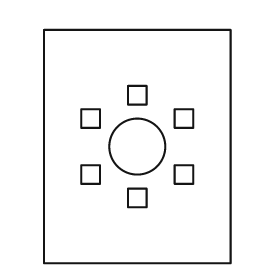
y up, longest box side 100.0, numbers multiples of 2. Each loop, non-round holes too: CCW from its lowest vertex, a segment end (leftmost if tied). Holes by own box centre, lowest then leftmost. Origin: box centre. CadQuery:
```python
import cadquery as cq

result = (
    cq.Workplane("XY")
    .moveTo(-40.0, -50.0)
    .lineTo(40.0, -50.0)
    .lineTo(40.0, 50.0)
    .lineTo(-40.0, 50.0)
    .close()
    .moveTo(-4.0, -26.0)
    .lineTo(4.0, -26.0)
    .lineTo(4.0, -18.0)
    .lineTo(-4.0, -18.0)
    .close()
    .moveTo(-24.0, -16.0)
    .lineTo(-16.0, -16.0)
    .lineTo(-16.0, -8.0)
    .lineTo(-24.0, -8.0)
    .close()
    .moveTo(16.0, -16.0)
    .lineTo(24.0, -16.0)
    .lineTo(24.0, -8.0)
    .lineTo(16.0, -8.0)
    .close()
    .moveTo(0.0, 0.0)
    .circle(12.0)
    .moveTo(-24.0, 8.0)
    .lineTo(-16.0, 8.0)
    .lineTo(-16.0, 16.0)
    .lineTo(-24.0, 16.0)
    .close()
    .moveTo(16.0, 8.0)
    .lineTo(24.0, 8.0)
    .lineTo(24.0, 16.0)
    .lineTo(16.0, 16.0)
    .close()
    .moveTo(-4.0, 18.0)
    .lineTo(4.0, 18.0)
    .lineTo(4.0, 26.0)
    .lineTo(-4.0, 26.0)
    .close()
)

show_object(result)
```